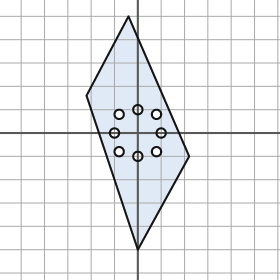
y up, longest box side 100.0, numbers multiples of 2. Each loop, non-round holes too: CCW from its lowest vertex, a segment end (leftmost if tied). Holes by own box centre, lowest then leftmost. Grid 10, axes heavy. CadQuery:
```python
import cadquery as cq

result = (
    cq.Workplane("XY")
    .moveTo(0.0, -50.0)
    .lineTo(22.0, -10.0)
    .lineTo(-4.0, 50.0)
    .lineTo(-22.0, 16.0)
    .close()
    .moveTo(0.0, -10.0)
    .circle(2.0)
    .moveTo(-8.0, -8.0)
    .circle(2.0)
    .moveTo(8.0, -8.0)
    .circle(2.0)
    .moveTo(-10.0, 0.0)
    .circle(2.0)
    .moveTo(10.0, 0.0)
    .circle(2.0)
    .moveTo(-8.0, 8.0)
    .circle(2.0)
    .moveTo(8.0, 8.0)
    .circle(2.0)
    .moveTo(0.0, 10.0)
    .circle(2.0)
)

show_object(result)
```